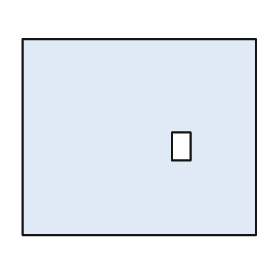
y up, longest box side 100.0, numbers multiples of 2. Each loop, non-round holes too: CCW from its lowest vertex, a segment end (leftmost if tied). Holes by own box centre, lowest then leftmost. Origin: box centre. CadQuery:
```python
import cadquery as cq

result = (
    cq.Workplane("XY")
    .moveTo(-50.0, -42.0)
    .lineTo(50.0, -42.0)
    .lineTo(50.0, 42.0)
    .lineTo(-50.0, 42.0)
    .close()
    .moveTo(14.0, -10.0)
    .lineTo(22.0, -10.0)
    .lineTo(22.0, 2.0)
    .lineTo(14.0, 2.0)
    .close()
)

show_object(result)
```